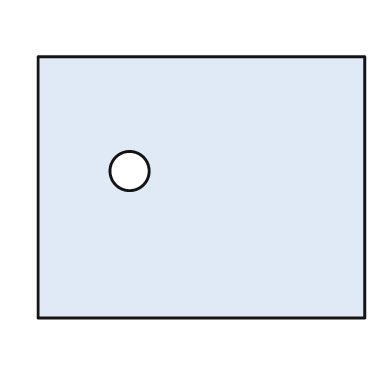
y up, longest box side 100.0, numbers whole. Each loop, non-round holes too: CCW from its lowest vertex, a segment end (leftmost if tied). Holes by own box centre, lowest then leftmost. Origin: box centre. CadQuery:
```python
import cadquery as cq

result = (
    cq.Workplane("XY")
    .moveTo(-50.0, -40.0)
    .lineTo(50.0, -40.0)
    .lineTo(50.0, 40.0)
    .lineTo(-50.0, 40.0)
    .close()
    .moveTo(-22.0, 5.0)
    .circle(6.0)
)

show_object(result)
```